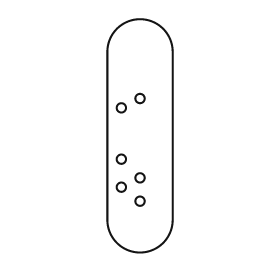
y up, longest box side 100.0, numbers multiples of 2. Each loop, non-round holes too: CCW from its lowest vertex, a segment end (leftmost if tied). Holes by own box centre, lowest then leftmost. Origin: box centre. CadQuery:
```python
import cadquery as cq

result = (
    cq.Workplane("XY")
    .moveTo(-14.0, -36.0)
    .threePointArc((0.0, -50.0), (14.0, -36.0))
    .lineTo(14.0, 36.0)
    .threePointArc((0.0, 50.0), (-14.0, 36.0))
    .close()
    .moveTo(0.0, -28.0)
    .circle(2.0)
    .moveTo(-8.0, -22.0)
    .circle(2.0)
    .moveTo(0.0, -18.0)
    .circle(2.0)
    .moveTo(-8.0, -10.0)
    .circle(2.0)
    .moveTo(-8.0, 12.0)
    .circle(2.0)
    .moveTo(0.0, 16.0)
    .circle(2.0)
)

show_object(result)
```